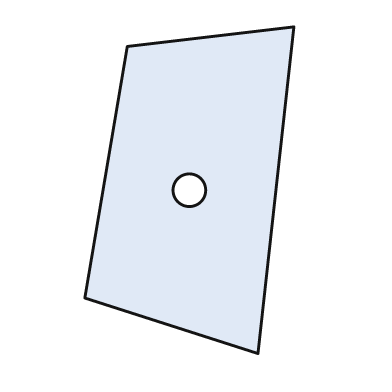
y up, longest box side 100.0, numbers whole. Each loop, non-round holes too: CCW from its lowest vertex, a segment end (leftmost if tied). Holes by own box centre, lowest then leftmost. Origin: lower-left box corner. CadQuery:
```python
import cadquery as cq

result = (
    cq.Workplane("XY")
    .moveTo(53.0, 0.0)
    .lineTo(64.0, 100.0)
    .lineTo(13.0, 94.0)
    .lineTo(0.0, 17.0)
    .close()
    .moveTo(32.0, 50.0)
    .circle(5.0)
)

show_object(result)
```